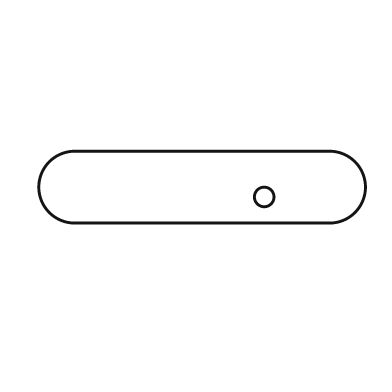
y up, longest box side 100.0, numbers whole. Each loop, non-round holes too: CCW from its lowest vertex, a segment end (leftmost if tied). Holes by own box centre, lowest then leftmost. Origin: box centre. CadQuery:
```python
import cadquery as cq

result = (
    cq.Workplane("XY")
    .moveTo(-39.0, -11.0)
    .lineTo(39.0, -11.0)
    .threePointArc((50.0, 0.0), (39.0, 11.0))
    .lineTo(-39.0, 11.0)
    .threePointArc((-50.0, 0.0), (-39.0, -11.0))
    .close()
    .moveTo(19.0, -3.0)
    .circle(3.0)
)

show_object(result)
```